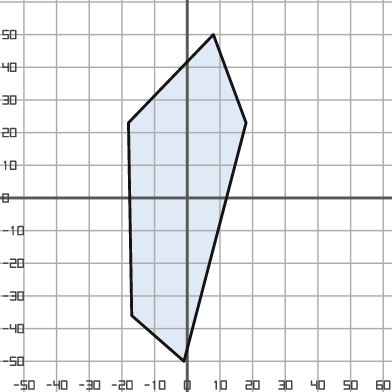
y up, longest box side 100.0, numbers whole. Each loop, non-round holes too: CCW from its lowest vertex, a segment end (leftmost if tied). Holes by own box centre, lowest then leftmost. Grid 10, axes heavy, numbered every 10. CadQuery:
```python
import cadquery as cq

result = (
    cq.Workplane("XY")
    .moveTo(-1.0, -50.0)
    .lineTo(18.0, 23.0)
    .lineTo(8.0, 50.0)
    .lineTo(-18.0, 23.0)
    .lineTo(-17.0, -36.0)
    .close()
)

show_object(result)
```